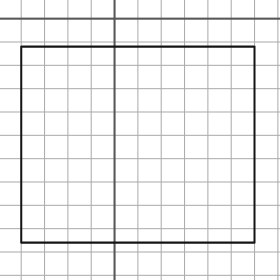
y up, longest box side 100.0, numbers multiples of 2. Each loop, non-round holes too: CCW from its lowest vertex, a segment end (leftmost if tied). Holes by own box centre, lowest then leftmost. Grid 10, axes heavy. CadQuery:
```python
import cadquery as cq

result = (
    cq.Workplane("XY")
    .moveTo(-40.0, -96.0)
    .lineTo(60.0, -96.0)
    .lineTo(60.0, -12.0)
    .lineTo(-40.0, -12.0)
    .close()
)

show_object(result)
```